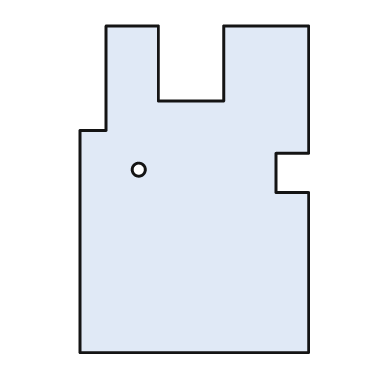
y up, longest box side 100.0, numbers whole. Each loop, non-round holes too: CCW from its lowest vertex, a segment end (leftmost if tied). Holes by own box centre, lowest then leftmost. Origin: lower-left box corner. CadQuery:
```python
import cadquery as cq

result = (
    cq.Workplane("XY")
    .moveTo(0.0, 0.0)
    .lineTo(70.0, 0.0)
    .lineTo(70.0, 49.0)
    .lineTo(60.0, 49.0)
    .lineTo(60.0, 61.0)
    .lineTo(70.0, 61.0)
    .lineTo(70.0, 100.0)
    .lineTo(44.0, 100.0)
    .lineTo(44.0, 77.0)
    .lineTo(24.0, 77.0)
    .lineTo(24.0, 100.0)
    .lineTo(8.0, 100.0)
    .lineTo(8.0, 68.0)
    .lineTo(0.0, 68.0)
    .close()
    .moveTo(18.0, 56.0)
    .circle(2.0)
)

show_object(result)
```